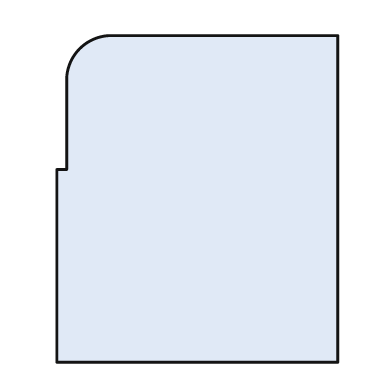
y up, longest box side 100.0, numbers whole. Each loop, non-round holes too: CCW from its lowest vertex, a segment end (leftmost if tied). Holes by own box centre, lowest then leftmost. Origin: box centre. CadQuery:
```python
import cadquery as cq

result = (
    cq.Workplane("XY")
    .moveTo(-43.0, -50.0)
    .lineTo(43.0, -50.0)
    .lineTo(43.0, 50.0)
    .lineTo(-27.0, 50.0)
    .threePointArc((-36.0, 46.0), (-40.0, 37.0))
    .lineTo(-40.0, 9.0)
    .lineTo(-43.0, 9.0)
    .close()
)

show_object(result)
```